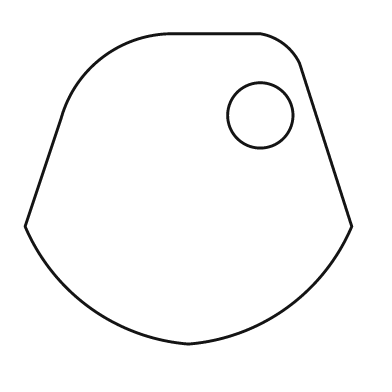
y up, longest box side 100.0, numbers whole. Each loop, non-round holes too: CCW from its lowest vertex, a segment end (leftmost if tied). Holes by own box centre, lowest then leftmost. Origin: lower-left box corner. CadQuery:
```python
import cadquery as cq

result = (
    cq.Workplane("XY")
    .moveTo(50.0, 0.0)
    .threePointArc((80.0, 11.0), (100.0, 36.0))
    .lineTo(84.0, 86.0)
    .threePointArc((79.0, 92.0), (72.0, 95.0))
    .lineTo(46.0, 95.0)
    .threePointArc((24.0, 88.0), (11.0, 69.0))
    .lineTo(0.0, 36.0)
    .threePointArc((20.0, 11.0), (50.0, 0.0))
    .close()
    .moveTo(72.0, 70.0)
    .circle(10.0)
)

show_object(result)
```